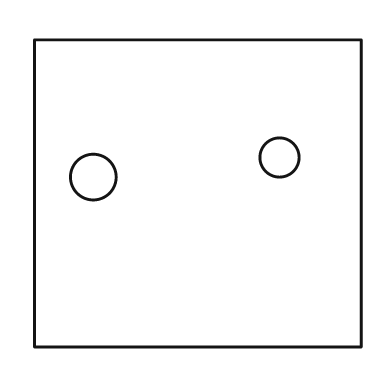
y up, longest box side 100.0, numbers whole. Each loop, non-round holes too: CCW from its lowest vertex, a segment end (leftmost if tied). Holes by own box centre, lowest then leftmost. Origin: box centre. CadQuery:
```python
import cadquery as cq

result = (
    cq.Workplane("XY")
    .moveTo(-50.0, -47.0)
    .lineTo(50.0, -47.0)
    .lineTo(50.0, 47.0)
    .lineTo(-50.0, 47.0)
    .close()
    .moveTo(-32.0, 5.0)
    .circle(7.0)
    .moveTo(25.0, 11.0)
    .circle(6.0)
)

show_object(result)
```